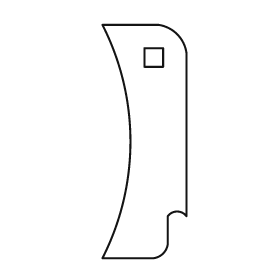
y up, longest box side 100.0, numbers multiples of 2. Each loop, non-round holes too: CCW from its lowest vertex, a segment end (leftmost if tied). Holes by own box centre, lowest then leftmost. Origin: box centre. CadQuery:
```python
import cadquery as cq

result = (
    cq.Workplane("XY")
    .moveTo(-18.0, -50.0)
    .lineTo(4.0, -50.0)
    .threePointArc((8.0, -48.0), (10.0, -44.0))
    .lineTo(10.0, -32.0)
    .threePointArc((14.0, -30.0), (18.0, -32.0))
    .lineTo(18.0, 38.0)
    .threePointArc((14.0, 46.0), (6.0, 50.0))
    .lineTo(-18.0, 50.0)
    .threePointArc((-6.0, 0.0), (-18.0, -50.0))
    .close()
    .moveTo(0.0, 32.0)
    .lineTo(8.0, 32.0)
    .lineTo(8.0, 40.0)
    .lineTo(0.0, 40.0)
    .close()
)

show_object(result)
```